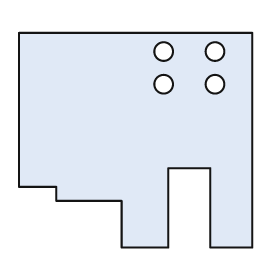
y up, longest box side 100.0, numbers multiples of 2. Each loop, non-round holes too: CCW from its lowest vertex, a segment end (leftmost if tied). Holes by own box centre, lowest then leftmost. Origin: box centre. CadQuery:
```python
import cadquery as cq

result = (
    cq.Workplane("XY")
    .moveTo(-6.0, -46.0)
    .lineTo(14.0, -46.0)
    .lineTo(14.0, -12.0)
    .lineTo(32.0, -12.0)
    .lineTo(32.0, -46.0)
    .lineTo(50.0, -46.0)
    .lineTo(50.0, 46.0)
    .lineTo(-50.0, 46.0)
    .lineTo(-50.0, -20.0)
    .lineTo(-34.0, -20.0)
    .lineTo(-34.0, -26.0)
    .lineTo(-6.0, -26.0)
    .close()
    .moveTo(12.0, 24.0)
    .circle(4.0)
    .moveTo(34.0, 24.0)
    .circle(4.0)
    .moveTo(12.0, 38.0)
    .circle(4.0)
    .moveTo(34.0, 38.0)
    .circle(4.0)
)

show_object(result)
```